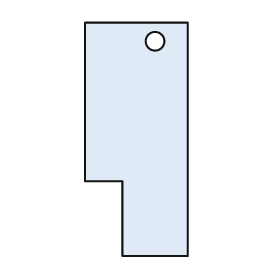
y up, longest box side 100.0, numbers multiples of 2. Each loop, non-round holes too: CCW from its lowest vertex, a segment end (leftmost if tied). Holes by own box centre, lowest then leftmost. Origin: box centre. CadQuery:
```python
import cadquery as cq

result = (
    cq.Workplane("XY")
    .moveTo(-6.0, -50.0)
    .lineTo(22.0, -50.0)
    .lineTo(22.0, 50.0)
    .lineTo(-22.0, 50.0)
    .lineTo(-22.0, -18.0)
    .lineTo(-6.0, -18.0)
    .close()
    .moveTo(8.0, 42.0)
    .circle(4.0)
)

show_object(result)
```